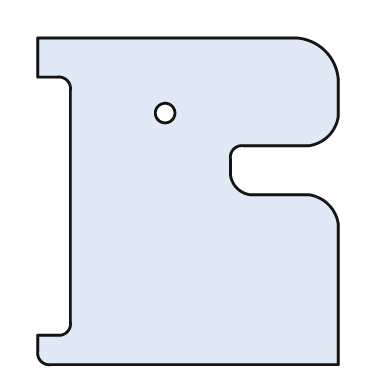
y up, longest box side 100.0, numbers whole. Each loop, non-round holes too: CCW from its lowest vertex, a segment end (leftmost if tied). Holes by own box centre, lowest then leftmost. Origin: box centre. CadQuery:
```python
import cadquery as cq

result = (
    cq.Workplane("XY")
    .moveTo(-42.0, -50.0)
    .lineTo(46.0, -50.0)
    .lineTo(46.0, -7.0)
    .threePointArc((43.0, -1.0), (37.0, 2.0))
    .lineTo(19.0, 2.0)
    .threePointArc((15.0, 4.0), (13.0, 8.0))
    .lineTo(13.0, 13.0)
    .threePointArc((14.0, 16.0), (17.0, 17.0))
    .lineTo(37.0, 17.0)
    .threePointArc((43.0, 20.0), (46.0, 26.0))
    .lineTo(46.0, 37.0)
    .threePointArc((42.0, 46.0), (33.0, 50.0))
    .lineTo(-46.0, 50.0)
    .lineTo(-46.0, 38.0)
    .lineTo(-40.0, 38.0)
    .threePointArc((-37.0, 37.0), (-36.0, 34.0))
    .lineTo(-36.0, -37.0)
    .threePointArc((-37.0, -40.0), (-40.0, -41.0))
    .lineTo(-46.0, -41.0)
    .lineTo(-46.0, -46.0)
    .threePointArc((-45.0, -49.0), (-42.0, -50.0))
    .close()
    .moveTo(-7.0, 27.0)
    .circle(3.0)
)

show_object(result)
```